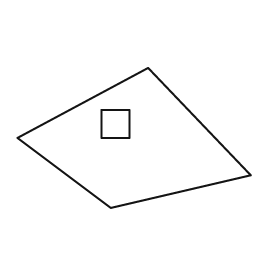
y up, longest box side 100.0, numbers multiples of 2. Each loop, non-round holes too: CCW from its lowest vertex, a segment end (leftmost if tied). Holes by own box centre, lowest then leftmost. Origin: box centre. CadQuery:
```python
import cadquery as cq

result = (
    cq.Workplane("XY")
    .moveTo(-10.0, -30.0)
    .lineTo(50.0, -16.0)
    .lineTo(6.0, 30.0)
    .lineTo(-50.0, 0.0)
    .close()
    .moveTo(-14.0, 0.0)
    .lineTo(-2.0, 0.0)
    .lineTo(-2.0, 12.0)
    .lineTo(-14.0, 12.0)
    .close()
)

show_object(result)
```